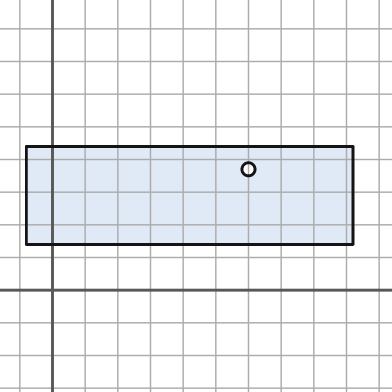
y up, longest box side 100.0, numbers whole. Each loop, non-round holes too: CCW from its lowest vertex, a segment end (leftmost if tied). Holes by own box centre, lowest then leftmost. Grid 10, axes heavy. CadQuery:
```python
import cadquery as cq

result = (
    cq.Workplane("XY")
    .moveTo(-8.0, 14.0)
    .lineTo(92.0, 14.0)
    .lineTo(92.0, 44.0)
    .lineTo(-8.0, 44.0)
    .close()
    .moveTo(60.0, 37.0)
    .circle(2.0)
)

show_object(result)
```